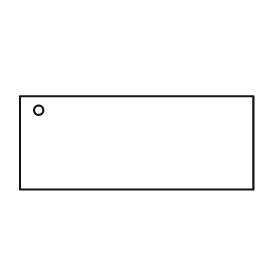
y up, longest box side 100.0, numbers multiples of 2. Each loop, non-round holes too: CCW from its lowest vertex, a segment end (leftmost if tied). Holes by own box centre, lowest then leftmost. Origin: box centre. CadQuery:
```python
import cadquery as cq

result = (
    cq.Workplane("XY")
    .moveTo(-50.0, -20.0)
    .lineTo(50.0, -20.0)
    .lineTo(50.0, 20.0)
    .lineTo(-50.0, 20.0)
    .close()
    .moveTo(-42.0, 14.0)
    .circle(2.0)
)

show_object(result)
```